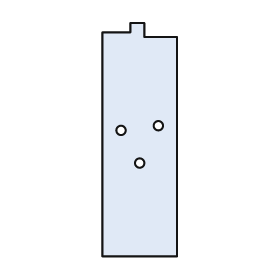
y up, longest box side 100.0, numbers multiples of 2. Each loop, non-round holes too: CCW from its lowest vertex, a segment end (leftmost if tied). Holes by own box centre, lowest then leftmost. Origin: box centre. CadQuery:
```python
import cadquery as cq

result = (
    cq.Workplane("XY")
    .moveTo(-16.0, -50.0)
    .lineTo(16.0, -50.0)
    .lineTo(16.0, 44.0)
    .lineTo(2.0, 44.0)
    .lineTo(2.0, 50.0)
    .lineTo(-4.0, 50.0)
    .lineTo(-4.0, 46.0)
    .lineTo(-16.0, 46.0)
    .close()
    .moveTo(0.0, -10.0)
    .circle(2.0)
    .moveTo(-8.0, 4.0)
    .circle(2.0)
    .moveTo(8.0, 6.0)
    .circle(2.0)
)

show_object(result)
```